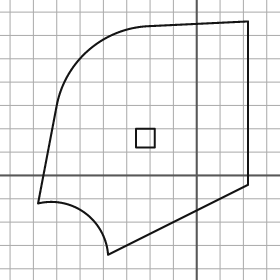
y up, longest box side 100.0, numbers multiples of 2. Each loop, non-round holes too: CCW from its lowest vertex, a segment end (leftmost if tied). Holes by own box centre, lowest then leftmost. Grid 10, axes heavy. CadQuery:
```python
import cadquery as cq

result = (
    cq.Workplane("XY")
    .moveTo(-38.0, -34.0)
    .lineTo(22.0, -4.0)
    .lineTo(22.0, 66.0)
    .lineTo(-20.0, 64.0)
    .threePointArc((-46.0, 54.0), (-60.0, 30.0))
    .lineTo(-68.0, -12.0)
    .threePointArc((-48.0, -16.0), (-38.0, -34.0))
    .close()
    .moveTo(-26.0, 12.0)
    .lineTo(-18.0, 12.0)
    .lineTo(-18.0, 20.0)
    .lineTo(-26.0, 20.0)
    .close()
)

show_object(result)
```